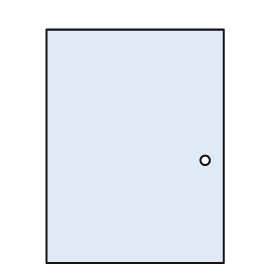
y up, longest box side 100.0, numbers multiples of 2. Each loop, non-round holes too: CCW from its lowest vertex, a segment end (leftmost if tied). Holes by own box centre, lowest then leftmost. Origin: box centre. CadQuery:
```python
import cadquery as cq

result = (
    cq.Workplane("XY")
    .moveTo(-38.0, -50.0)
    .lineTo(38.0, -50.0)
    .lineTo(38.0, 50.0)
    .lineTo(-38.0, 50.0)
    .close()
    .moveTo(30.0, -6.0)
    .circle(2.0)
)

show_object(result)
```